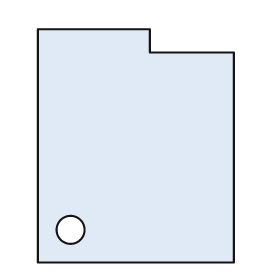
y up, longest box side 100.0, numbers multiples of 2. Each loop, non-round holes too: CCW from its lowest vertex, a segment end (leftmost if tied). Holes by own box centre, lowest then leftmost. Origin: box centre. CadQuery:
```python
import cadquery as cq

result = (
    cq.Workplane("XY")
    .moveTo(-42.0, -50.0)
    .lineTo(42.0, -50.0)
    .lineTo(42.0, 40.0)
    .lineTo(6.0, 40.0)
    .lineTo(6.0, 50.0)
    .lineTo(-42.0, 50.0)
    .close()
    .moveTo(-28.0, -36.0)
    .circle(6.0)
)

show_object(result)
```